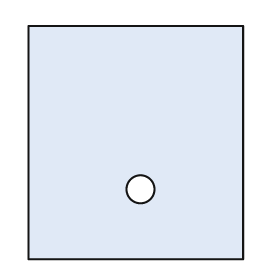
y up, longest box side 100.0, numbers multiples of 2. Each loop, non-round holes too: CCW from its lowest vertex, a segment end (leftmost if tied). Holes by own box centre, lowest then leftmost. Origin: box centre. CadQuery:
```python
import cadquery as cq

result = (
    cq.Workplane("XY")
    .moveTo(-46.0, -50.0)
    .lineTo(46.0, -50.0)
    .lineTo(46.0, 50.0)
    .lineTo(-46.0, 50.0)
    .close()
    .moveTo(2.0, -20.0)
    .circle(6.0)
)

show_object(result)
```